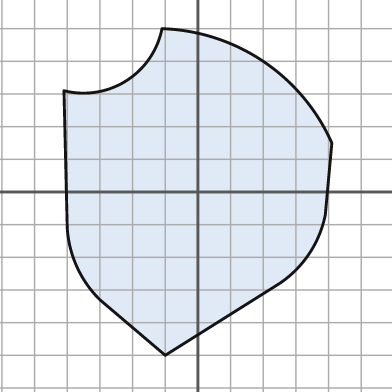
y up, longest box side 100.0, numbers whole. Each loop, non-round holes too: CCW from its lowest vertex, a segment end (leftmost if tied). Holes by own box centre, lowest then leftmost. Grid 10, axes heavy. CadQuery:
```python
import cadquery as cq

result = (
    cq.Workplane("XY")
    .moveTo(-10.0, -50.0)
    .lineTo(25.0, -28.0)
    .threePointArc((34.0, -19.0), (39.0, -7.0))
    .lineTo(41.0, 15.0)
    .threePointArc((20.0, 40.0), (-11.0, 50.0))
    .threePointArc((-22.0, 34.0), (-41.0, 31.0))
    .lineTo(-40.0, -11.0)
    .threePointArc((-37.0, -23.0), (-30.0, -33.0))
    .close()
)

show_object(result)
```